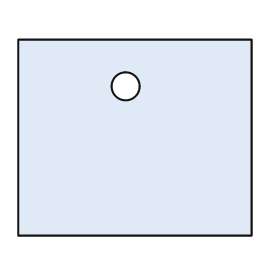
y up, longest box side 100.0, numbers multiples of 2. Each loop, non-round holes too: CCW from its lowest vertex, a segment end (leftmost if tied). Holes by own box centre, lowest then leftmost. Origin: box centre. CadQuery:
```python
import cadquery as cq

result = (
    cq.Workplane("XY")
    .moveTo(-50.0, -42.0)
    .lineTo(50.0, -42.0)
    .lineTo(50.0, 42.0)
    .lineTo(-50.0, 42.0)
    .close()
    .moveTo(-4.0, 22.0)
    .circle(6.0)
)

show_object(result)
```